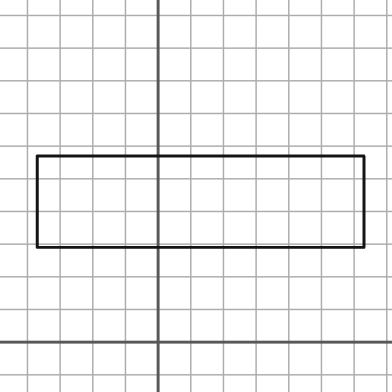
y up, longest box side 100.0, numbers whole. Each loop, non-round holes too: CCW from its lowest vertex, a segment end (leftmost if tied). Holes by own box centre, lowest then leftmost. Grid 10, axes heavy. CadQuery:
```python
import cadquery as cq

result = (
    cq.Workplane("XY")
    .moveTo(-37.0, 29.0)
    .lineTo(63.0, 29.0)
    .lineTo(63.0, 57.0)
    .lineTo(-37.0, 57.0)
    .close()
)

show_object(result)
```